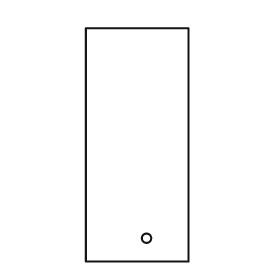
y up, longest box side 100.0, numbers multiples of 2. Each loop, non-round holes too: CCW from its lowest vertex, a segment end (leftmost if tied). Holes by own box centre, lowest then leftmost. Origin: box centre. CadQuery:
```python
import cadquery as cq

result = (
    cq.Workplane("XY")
    .moveTo(-22.0, -50.0)
    .lineTo(22.0, -50.0)
    .lineTo(22.0, 50.0)
    .lineTo(-22.0, 50.0)
    .close()
    .moveTo(4.0, -40.0)
    .circle(2.0)
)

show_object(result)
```